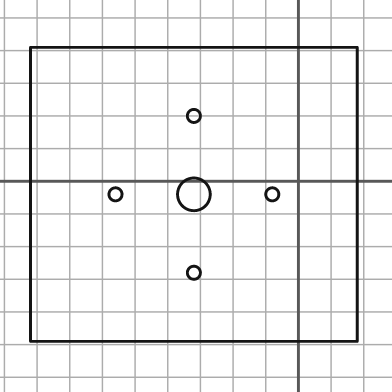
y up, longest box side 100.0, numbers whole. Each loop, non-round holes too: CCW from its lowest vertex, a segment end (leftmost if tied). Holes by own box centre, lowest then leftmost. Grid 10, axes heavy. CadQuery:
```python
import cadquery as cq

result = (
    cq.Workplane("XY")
    .moveTo(-82.0, -49.0)
    .lineTo(18.0, -49.0)
    .lineTo(18.0, 41.0)
    .lineTo(-82.0, 41.0)
    .close()
    .moveTo(-32.0, -28.0)
    .circle(2.0)
    .moveTo(-56.0, -4.0)
    .circle(2.0)
    .moveTo(-32.0, -4.0)
    .circle(5.0)
    .moveTo(-8.0, -4.0)
    .circle(2.0)
    .moveTo(-32.0, 20.0)
    .circle(2.0)
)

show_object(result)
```